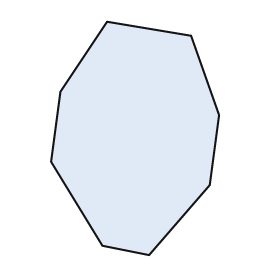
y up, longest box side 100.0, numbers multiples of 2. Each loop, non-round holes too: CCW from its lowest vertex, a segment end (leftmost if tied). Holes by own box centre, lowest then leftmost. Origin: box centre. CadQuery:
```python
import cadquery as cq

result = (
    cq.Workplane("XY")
    .moveTo(6.0, -50.0)
    .lineTo(32.0, -20.0)
    .lineTo(36.0, 10.0)
    .lineTo(24.0, 44.0)
    .lineTo(-12.0, 50.0)
    .lineTo(-32.0, 20.0)
    .lineTo(-36.0, -10.0)
    .lineTo(-14.0, -46.0)
    .close()
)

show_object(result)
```